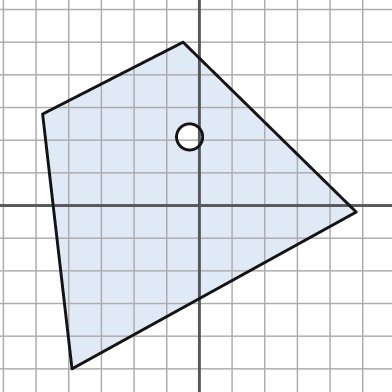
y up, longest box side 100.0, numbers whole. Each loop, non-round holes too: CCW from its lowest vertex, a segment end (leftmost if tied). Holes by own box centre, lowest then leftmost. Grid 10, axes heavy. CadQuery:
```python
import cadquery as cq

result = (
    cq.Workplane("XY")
    .moveTo(-39.0, -50.0)
    .lineTo(48.0, -2.0)
    .lineTo(-5.0, 50.0)
    .lineTo(-48.0, 28.0)
    .close()
    .moveTo(-3.0, 21.0)
    .circle(4.0)
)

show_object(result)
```